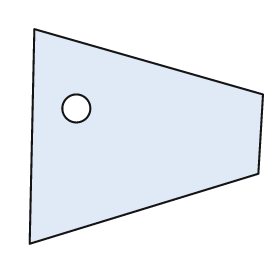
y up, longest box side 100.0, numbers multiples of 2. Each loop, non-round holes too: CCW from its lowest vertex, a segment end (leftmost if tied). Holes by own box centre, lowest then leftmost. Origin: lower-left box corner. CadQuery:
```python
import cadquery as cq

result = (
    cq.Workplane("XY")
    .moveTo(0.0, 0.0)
    .lineTo(98.0, 30.0)
    .lineTo(100.0, 64.0)
    .lineTo(2.0, 92.0)
    .close()
    .moveTo(20.0, 58.0)
    .circle(6.0)
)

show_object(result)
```